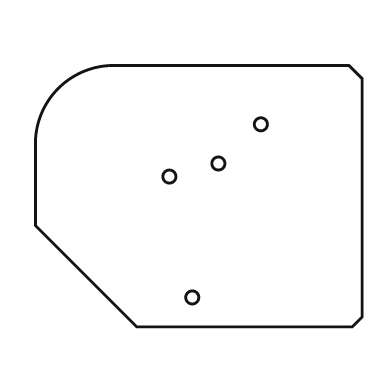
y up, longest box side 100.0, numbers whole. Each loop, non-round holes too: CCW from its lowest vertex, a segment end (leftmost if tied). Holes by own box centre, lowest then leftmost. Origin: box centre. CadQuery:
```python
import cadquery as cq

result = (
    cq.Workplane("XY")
    .moveTo(-19.0, -40.0)
    .lineTo(47.0, -40.0)
    .lineTo(50.0, -37.0)
    .lineTo(50.0, 36.0)
    .lineTo(46.0, 40.0)
    .lineTo(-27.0, 40.0)
    .threePointArc((-43.0, 33.0), (-50.0, 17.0))
    .lineTo(-50.0, -9.0)
    .close()
    .moveTo(-2.0, -31.0)
    .circle(2.0)
    .moveTo(-9.0, 6.0)
    .circle(2.0)
    .moveTo(6.0, 10.0)
    .circle(2.0)
    .moveTo(19.0, 22.0)
    .circle(2.0)
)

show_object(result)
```